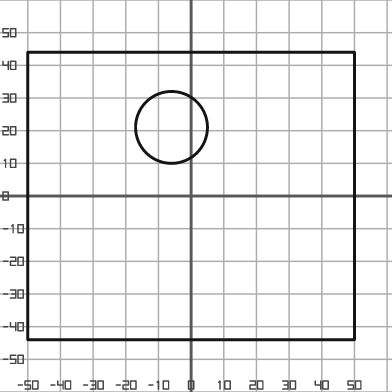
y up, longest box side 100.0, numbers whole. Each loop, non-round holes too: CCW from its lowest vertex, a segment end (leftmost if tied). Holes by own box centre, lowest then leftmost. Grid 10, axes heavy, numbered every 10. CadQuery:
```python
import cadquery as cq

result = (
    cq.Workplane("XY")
    .moveTo(-50.0, -44.0)
    .lineTo(50.0, -44.0)
    .lineTo(50.0, 44.0)
    .lineTo(-50.0, 44.0)
    .close()
    .moveTo(-6.0, 21.0)
    .circle(11.0)
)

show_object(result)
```